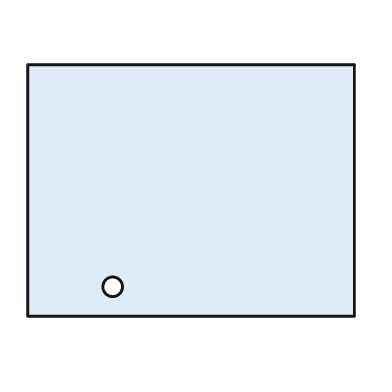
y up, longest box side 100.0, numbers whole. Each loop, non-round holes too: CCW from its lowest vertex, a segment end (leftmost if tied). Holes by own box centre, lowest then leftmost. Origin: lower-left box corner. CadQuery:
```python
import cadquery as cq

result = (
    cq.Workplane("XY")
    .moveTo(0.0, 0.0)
    .lineTo(100.0, 0.0)
    .lineTo(100.0, 77.0)
    .lineTo(0.0, 77.0)
    .close()
    .moveTo(26.0, 9.0)
    .circle(3.0)
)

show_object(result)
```